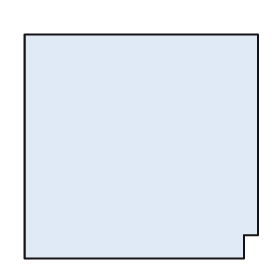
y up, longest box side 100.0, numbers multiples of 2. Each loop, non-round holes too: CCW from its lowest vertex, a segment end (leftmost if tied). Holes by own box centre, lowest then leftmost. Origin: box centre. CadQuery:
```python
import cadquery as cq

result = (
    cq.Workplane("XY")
    .moveTo(-50.0, -48.0)
    .lineTo(44.0, -48.0)
    .lineTo(44.0, -38.0)
    .lineTo(50.0, -38.0)
    .lineTo(50.0, 48.0)
    .lineTo(-50.0, 48.0)
    .close()
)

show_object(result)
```